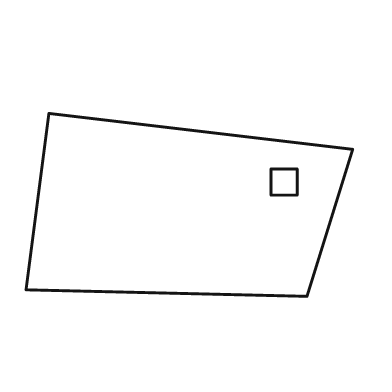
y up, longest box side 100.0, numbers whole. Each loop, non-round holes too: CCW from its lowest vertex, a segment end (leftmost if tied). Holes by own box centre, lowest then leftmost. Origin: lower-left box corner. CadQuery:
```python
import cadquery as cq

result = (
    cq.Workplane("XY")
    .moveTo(86.0, 0.0)
    .lineTo(100.0, 45.0)
    .lineTo(7.0, 56.0)
    .lineTo(0.0, 2.0)
    .close()
    .moveTo(75.0, 31.0)
    .lineTo(83.0, 31.0)
    .lineTo(83.0, 39.0)
    .lineTo(75.0, 39.0)
    .close()
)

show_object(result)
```